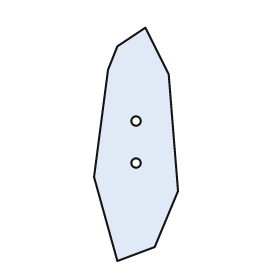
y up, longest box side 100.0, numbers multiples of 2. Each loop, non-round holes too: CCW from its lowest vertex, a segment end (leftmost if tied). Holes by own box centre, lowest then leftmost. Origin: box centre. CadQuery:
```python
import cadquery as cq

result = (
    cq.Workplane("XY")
    .moveTo(-8.0, -50.0)
    .lineTo(8.0, -44.0)
    .lineTo(18.0, -20.0)
    .lineTo(14.0, 30.0)
    .lineTo(4.0, 50.0)
    .lineTo(-8.0, 42.0)
    .lineTo(-12.0, 32.0)
    .lineTo(-18.0, -14.0)
    .close()
    .moveTo(0.0, -8.0)
    .circle(2.0)
    .moveTo(0.0, 10.0)
    .circle(2.0)
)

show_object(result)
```